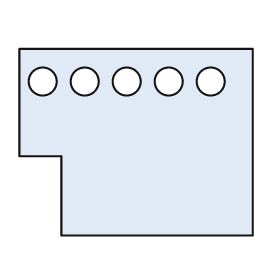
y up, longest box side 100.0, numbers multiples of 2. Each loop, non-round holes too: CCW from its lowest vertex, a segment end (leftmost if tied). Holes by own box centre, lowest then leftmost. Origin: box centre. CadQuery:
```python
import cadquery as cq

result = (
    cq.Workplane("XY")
    .moveTo(-32.0, -40.0)
    .lineTo(50.0, -40.0)
    .lineTo(50.0, 40.0)
    .lineTo(-50.0, 40.0)
    .lineTo(-50.0, -6.0)
    .lineTo(-32.0, -6.0)
    .close()
    .moveTo(-40.0, 26.0)
    .circle(6.0)
    .moveTo(-22.0, 26.0)
    .circle(6.0)
    .moveTo(-4.0, 26.0)
    .circle(6.0)
    .moveTo(14.0, 26.0)
    .circle(6.0)
    .moveTo(32.0, 26.0)
    .circle(6.0)
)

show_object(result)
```